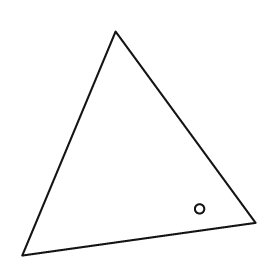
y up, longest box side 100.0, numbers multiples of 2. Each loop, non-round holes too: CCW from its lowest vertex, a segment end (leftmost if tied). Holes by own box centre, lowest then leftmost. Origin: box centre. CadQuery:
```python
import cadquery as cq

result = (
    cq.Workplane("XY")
    .moveTo(-50.0, -48.0)
    .lineTo(50.0, -34.0)
    .lineTo(-10.0, 48.0)
    .close()
    .moveTo(26.0, -28.0)
    .circle(2.0)
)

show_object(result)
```